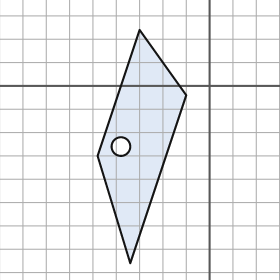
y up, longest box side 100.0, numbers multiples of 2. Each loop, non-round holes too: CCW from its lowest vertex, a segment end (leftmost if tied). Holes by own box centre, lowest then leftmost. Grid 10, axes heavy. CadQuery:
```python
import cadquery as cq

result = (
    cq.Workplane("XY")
    .moveTo(-34.0, -76.0)
    .lineTo(-10.0, -4.0)
    .lineTo(-30.0, 24.0)
    .lineTo(-48.0, -30.0)
    .close()
    .moveTo(-38.0, -26.0)
    .circle(4.0)
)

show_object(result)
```